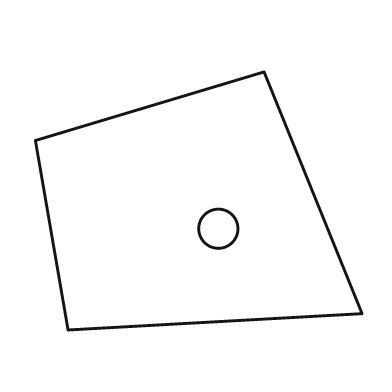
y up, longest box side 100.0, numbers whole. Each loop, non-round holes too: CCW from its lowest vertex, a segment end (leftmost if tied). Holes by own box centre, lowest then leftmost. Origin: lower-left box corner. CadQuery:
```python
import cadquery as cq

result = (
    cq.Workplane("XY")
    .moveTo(10.0, 0.0)
    .lineTo(100.0, 5.0)
    .lineTo(70.0, 79.0)
    .lineTo(0.0, 58.0)
    .close()
    .moveTo(56.0, 31.0)
    .circle(6.0)
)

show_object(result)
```